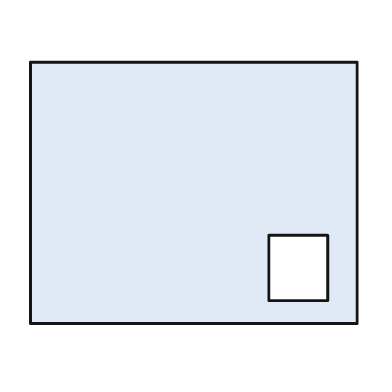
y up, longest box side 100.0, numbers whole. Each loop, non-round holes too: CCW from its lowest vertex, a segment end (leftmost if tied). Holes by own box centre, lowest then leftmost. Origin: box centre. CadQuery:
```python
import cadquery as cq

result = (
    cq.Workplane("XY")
    .moveTo(-50.0, -40.0)
    .lineTo(50.0, -40.0)
    .lineTo(50.0, 40.0)
    .lineTo(-50.0, 40.0)
    .close()
    .moveTo(23.0, -33.0)
    .lineTo(41.0, -33.0)
    .lineTo(41.0, -13.0)
    .lineTo(23.0, -13.0)
    .close()
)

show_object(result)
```